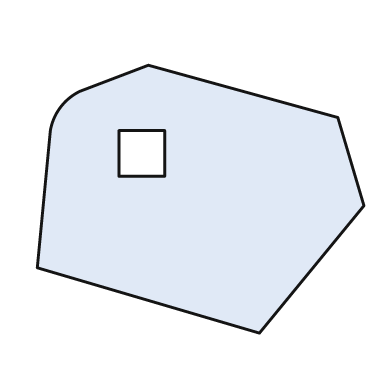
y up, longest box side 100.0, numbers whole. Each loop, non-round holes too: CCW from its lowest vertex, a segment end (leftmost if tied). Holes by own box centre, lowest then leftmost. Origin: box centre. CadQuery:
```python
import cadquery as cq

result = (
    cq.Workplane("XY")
    .moveTo(18.0, -41.0)
    .lineTo(50.0, -2.0)
    .lineTo(42.0, 25.0)
    .lineTo(-16.0, 41.0)
    .lineTo(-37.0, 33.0)
    .threePointArc((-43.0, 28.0), (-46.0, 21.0))
    .lineTo(-50.0, -21.0)
    .close()
    .moveTo(-25.0, 7.0)
    .lineTo(-11.0, 7.0)
    .lineTo(-11.0, 21.0)
    .lineTo(-25.0, 21.0)
    .close()
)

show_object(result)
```